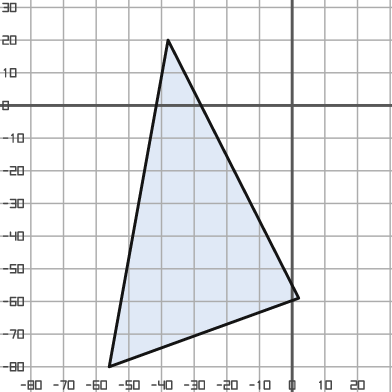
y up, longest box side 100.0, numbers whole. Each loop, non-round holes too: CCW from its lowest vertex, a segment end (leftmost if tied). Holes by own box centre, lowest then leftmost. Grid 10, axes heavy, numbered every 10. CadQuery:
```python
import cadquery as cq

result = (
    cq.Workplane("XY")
    .moveTo(-56.0, -80.0)
    .lineTo(2.0, -59.0)
    .lineTo(-38.0, 20.0)
    .close()
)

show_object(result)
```